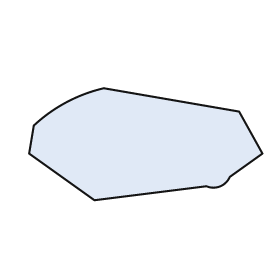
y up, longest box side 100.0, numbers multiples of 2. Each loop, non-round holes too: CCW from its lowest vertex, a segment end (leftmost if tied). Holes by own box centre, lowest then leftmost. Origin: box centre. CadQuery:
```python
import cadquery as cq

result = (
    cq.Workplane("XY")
    .moveTo(-22.0, -24.0)
    .lineTo(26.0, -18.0)
    .threePointArc((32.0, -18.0), (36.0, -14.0))
    .lineTo(50.0, -4.0)
    .lineTo(40.0, 14.0)
    .lineTo(-18.0, 24.0)
    .threePointArc((-34.0, 18.0), (-48.0, 8.0))
    .lineTo(-50.0, -4.0)
    .close()
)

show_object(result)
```